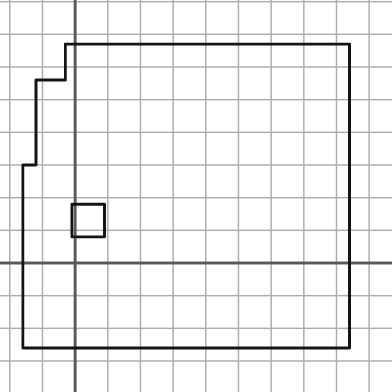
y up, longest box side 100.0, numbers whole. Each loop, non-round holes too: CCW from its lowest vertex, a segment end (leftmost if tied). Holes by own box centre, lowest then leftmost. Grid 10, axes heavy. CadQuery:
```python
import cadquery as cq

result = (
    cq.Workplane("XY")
    .moveTo(-16.0, -26.0)
    .lineTo(84.0, -26.0)
    .lineTo(84.0, 67.0)
    .lineTo(-3.0, 67.0)
    .lineTo(-3.0, 56.0)
    .lineTo(-12.0, 56.0)
    .lineTo(-12.0, 30.0)
    .lineTo(-16.0, 30.0)
    .close()
    .moveTo(-1.0, 8.0)
    .lineTo(9.0, 8.0)
    .lineTo(9.0, 18.0)
    .lineTo(-1.0, 18.0)
    .close()
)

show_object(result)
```